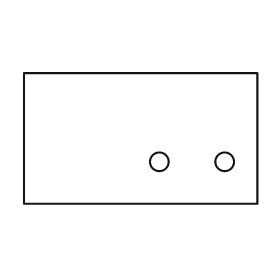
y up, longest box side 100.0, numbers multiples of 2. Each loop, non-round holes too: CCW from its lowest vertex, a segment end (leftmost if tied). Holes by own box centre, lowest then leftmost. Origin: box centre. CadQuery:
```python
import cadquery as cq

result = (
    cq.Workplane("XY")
    .moveTo(-50.0, -28.0)
    .lineTo(50.0, -28.0)
    .lineTo(50.0, 28.0)
    .lineTo(-50.0, 28.0)
    .close()
    .moveTo(8.0, -10.0)
    .circle(4.0)
    .moveTo(36.0, -10.0)
    .circle(4.0)
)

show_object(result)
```